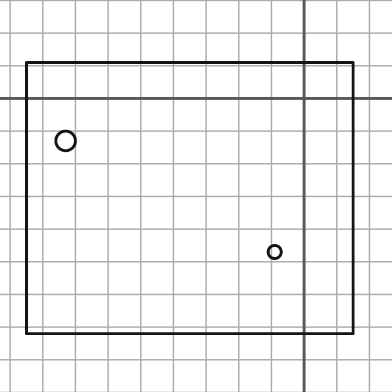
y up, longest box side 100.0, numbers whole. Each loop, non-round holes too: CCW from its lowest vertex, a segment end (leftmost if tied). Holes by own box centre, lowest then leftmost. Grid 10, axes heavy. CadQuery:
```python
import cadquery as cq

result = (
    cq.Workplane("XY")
    .moveTo(-85.0, -72.0)
    .lineTo(15.0, -72.0)
    .lineTo(15.0, 11.0)
    .lineTo(-85.0, 11.0)
    .close()
    .moveTo(-9.0, -47.0)
    .circle(2.0)
    .moveTo(-73.0, -13.0)
    .circle(3.0)
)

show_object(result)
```